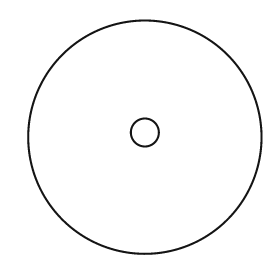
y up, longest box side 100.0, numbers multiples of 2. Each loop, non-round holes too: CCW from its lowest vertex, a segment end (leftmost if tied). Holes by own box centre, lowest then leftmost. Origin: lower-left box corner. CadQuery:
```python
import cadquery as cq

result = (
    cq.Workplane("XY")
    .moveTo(50.0, 50.0)
    .circle(50.0)
    .moveTo(50.0, 52.0)
    .circle(6.0)
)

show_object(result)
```